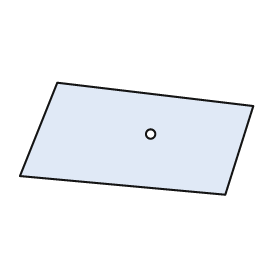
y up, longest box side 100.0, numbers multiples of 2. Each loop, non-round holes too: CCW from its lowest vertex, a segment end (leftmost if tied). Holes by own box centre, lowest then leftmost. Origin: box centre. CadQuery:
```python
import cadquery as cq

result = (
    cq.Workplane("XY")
    .moveTo(38.0, -24.0)
    .lineTo(50.0, 14.0)
    .lineTo(-34.0, 24.0)
    .lineTo(-50.0, -16.0)
    .close()
    .moveTo(6.0, 2.0)
    .circle(2.0)
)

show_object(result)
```